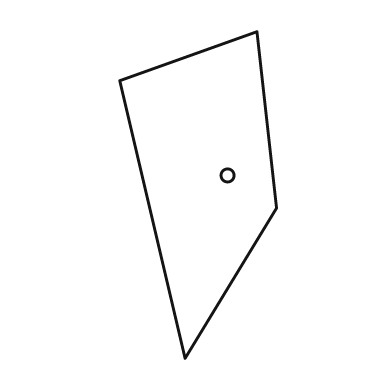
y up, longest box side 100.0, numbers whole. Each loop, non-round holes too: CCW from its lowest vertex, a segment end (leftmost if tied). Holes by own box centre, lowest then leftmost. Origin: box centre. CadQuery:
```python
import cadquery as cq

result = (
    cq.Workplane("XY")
    .moveTo(-4.0, -50.0)
    .lineTo(24.0, -4.0)
    .lineTo(18.0, 50.0)
    .lineTo(-24.0, 35.0)
    .close()
    .moveTo(9.0, 6.0)
    .circle(2.0)
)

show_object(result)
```